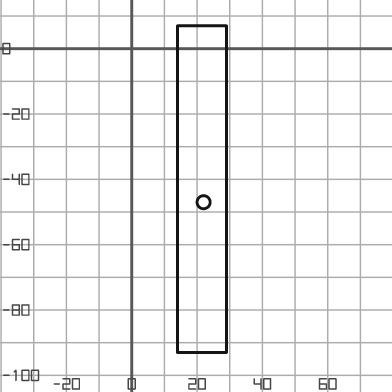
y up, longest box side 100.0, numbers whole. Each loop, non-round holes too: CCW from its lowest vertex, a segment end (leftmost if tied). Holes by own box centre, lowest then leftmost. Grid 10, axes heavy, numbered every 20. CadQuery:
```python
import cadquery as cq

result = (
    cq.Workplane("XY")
    .moveTo(14.0, -93.0)
    .lineTo(29.0, -93.0)
    .lineTo(29.0, 7.0)
    .lineTo(14.0, 7.0)
    .close()
    .moveTo(22.0, -47.0)
    .circle(2.0)
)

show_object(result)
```